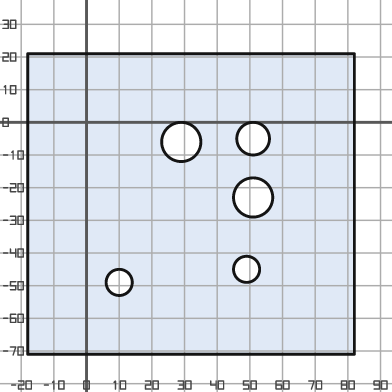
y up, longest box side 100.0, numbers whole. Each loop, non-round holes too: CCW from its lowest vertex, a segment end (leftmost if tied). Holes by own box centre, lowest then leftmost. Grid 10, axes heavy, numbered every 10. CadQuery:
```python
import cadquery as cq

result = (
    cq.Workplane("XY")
    .moveTo(-18.0, -71.0)
    .lineTo(82.0, -71.0)
    .lineTo(82.0, 21.0)
    .lineTo(-18.0, 21.0)
    .close()
    .moveTo(10.0, -49.0)
    .circle(4.0)
    .moveTo(49.0, -45.0)
    .circle(4.0)
    .moveTo(51.0, -23.0)
    .circle(6.0)
    .moveTo(29.0, -6.0)
    .circle(6.0)
    .moveTo(51.0, -5.0)
    .circle(5.0)
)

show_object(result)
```